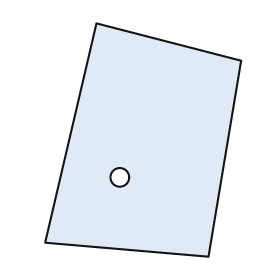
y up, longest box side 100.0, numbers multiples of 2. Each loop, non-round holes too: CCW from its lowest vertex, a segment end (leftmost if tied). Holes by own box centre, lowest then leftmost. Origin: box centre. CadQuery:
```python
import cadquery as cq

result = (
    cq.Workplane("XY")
    .moveTo(28.0, -50.0)
    .lineTo(42.0, 34.0)
    .lineTo(-20.0, 50.0)
    .lineTo(-42.0, -44.0)
    .close()
    .moveTo(-10.0, -16.0)
    .circle(4.0)
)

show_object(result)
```